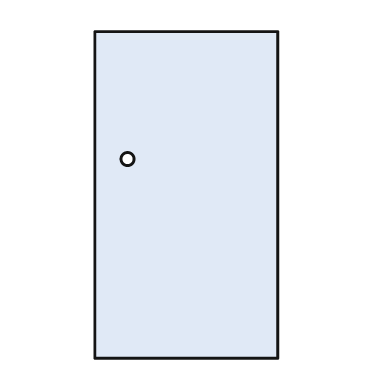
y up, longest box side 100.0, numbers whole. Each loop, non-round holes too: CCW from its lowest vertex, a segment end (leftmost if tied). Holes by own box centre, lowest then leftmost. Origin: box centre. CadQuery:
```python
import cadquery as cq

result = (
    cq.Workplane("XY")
    .moveTo(-28.0, -50.0)
    .lineTo(28.0, -50.0)
    .lineTo(28.0, 50.0)
    .lineTo(-28.0, 50.0)
    .close()
    .moveTo(-18.0, 11.0)
    .circle(2.0)
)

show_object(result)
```